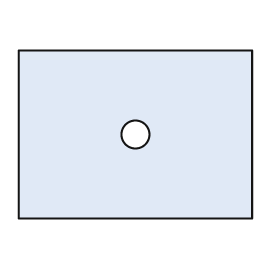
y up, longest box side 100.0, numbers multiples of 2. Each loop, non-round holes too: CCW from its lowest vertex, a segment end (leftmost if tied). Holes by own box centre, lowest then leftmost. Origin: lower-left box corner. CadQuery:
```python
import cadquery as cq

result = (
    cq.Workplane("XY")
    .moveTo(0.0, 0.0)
    .lineTo(100.0, 0.0)
    .lineTo(100.0, 72.0)
    .lineTo(0.0, 72.0)
    .close()
    .moveTo(50.0, 36.0)
    .circle(6.0)
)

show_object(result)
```